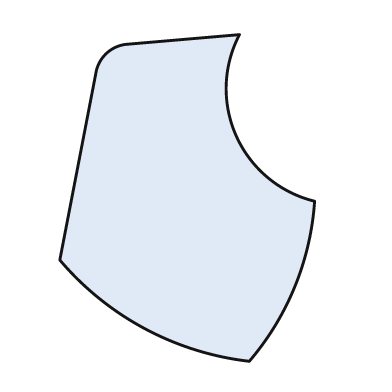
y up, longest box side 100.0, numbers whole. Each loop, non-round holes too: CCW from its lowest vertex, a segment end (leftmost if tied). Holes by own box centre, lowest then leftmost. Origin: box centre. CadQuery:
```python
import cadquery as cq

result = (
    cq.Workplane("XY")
    .moveTo(19.0, -50.0)
    .threePointArc((33.0, -27.0), (39.0, -1.0))
    .threePointArc((15.0, 19.0), (16.0, 50.0))
    .lineTo(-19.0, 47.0)
    .threePointArc((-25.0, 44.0), (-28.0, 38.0))
    .lineTo(-39.0, -19.0)
    .threePointArc((-13.0, -40.0), (19.0, -50.0))
    .close()
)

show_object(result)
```